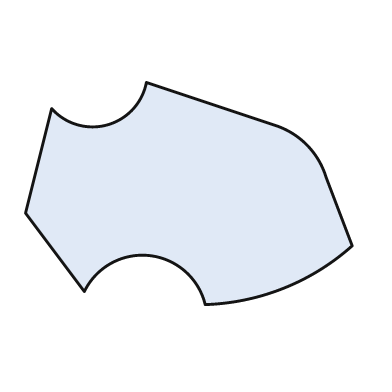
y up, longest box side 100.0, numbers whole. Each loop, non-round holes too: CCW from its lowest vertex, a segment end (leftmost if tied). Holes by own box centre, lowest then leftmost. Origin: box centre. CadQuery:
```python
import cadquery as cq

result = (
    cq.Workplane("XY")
    .moveTo(5.0, -34.0)
    .threePointArc((29.0, -29.0), (50.0, -16.0))
    .lineTo(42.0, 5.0)
    .threePointArc((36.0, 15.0), (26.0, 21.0))
    .lineTo(-13.0, 34.0)
    .threePointArc((-25.0, 21.0), (-42.0, 26.0))
    .lineTo(-50.0, -6.0)
    .lineTo(-32.0, -30.0)
    .threePointArc((-12.0, -19.0), (5.0, -34.0))
    .close()
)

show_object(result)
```